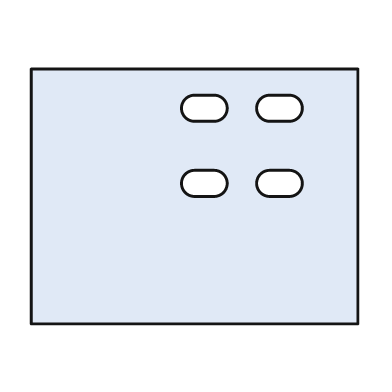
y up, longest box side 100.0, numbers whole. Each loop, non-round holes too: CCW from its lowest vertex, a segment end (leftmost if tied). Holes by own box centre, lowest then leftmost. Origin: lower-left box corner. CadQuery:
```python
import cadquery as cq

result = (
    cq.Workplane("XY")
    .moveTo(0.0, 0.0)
    .lineTo(100.0, 0.0)
    .lineTo(100.0, 78.0)
    .lineTo(0.0, 78.0)
    .close()
    .moveTo(50.0, 39.0)
    .lineTo(56.0, 39.0)
    .threePointArc((60.0, 43.0), (56.0, 47.0))
    .lineTo(50.0, 47.0)
    .threePointArc((46.0, 43.0), (50.0, 39.0))
    .close()
    .moveTo(73.0, 39.0)
    .lineTo(79.0, 39.0)
    .threePointArc((83.0, 43.0), (79.0, 47.0))
    .lineTo(73.0, 47.0)
    .threePointArc((69.0, 43.0), (73.0, 39.0))
    .close()
    .moveTo(50.0, 62.0)
    .lineTo(56.0, 62.0)
    .threePointArc((60.0, 66.0), (56.0, 70.0))
    .lineTo(50.0, 70.0)
    .threePointArc((46.0, 66.0), (50.0, 62.0))
    .close()
    .moveTo(73.0, 62.0)
    .lineTo(79.0, 62.0)
    .threePointArc((83.0, 66.0), (79.0, 70.0))
    .lineTo(73.0, 70.0)
    .threePointArc((69.0, 66.0), (73.0, 62.0))
    .close()
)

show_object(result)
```